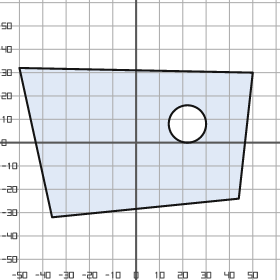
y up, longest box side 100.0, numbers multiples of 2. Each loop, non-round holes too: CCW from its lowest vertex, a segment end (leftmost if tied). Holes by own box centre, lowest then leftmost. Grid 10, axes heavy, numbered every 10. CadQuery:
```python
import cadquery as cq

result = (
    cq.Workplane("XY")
    .moveTo(-36.0, -32.0)
    .lineTo(44.0, -24.0)
    .lineTo(50.0, 30.0)
    .lineTo(-50.0, 32.0)
    .close()
    .moveTo(22.0, 8.0)
    .circle(8.0)
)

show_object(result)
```